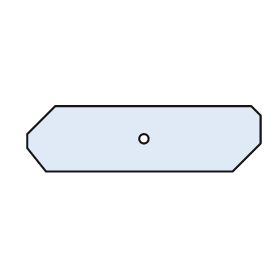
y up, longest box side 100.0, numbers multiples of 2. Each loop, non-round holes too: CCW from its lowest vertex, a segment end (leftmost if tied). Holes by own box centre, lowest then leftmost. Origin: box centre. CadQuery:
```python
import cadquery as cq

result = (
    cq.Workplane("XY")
    .moveTo(-42.0, -14.0)
    .lineTo(38.0, -14.0)
    .lineTo(50.0, -2.0)
    .lineTo(50.0, 10.0)
    .lineTo(46.0, 14.0)
    .lineTo(-38.0, 14.0)
    .lineTo(-50.0, 2.0)
    .lineTo(-50.0, -4.0)
    .close()
    .moveTo(0.0, 0.0)
    .circle(2.0)
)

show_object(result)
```